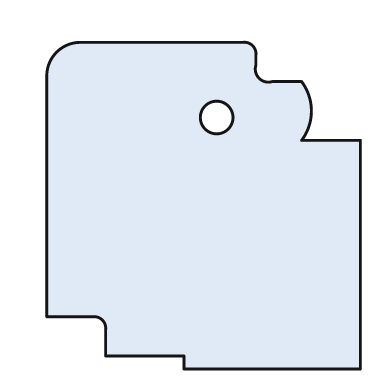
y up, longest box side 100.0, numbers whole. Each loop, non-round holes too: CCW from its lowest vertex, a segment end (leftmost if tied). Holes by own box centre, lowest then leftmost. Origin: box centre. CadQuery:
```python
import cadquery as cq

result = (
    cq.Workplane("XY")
    .moveTo(-6.0, -50.0)
    .lineTo(48.0, -50.0)
    .lineTo(48.0, 20.0)
    .lineTo(30.0, 20.0)
    .threePointArc((33.0, 29.0), (30.0, 38.0))
    .lineTo(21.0, 38.0)
    .threePointArc((17.0, 39.0), (16.0, 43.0))
    .lineTo(16.0, 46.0)
    .threePointArc((15.0, 49.0), (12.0, 50.0))
    .lineTo(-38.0, 50.0)
    .threePointArc((-45.0, 47.0), (-48.0, 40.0))
    .lineTo(-48.0, -34.0)
    .lineTo(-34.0, -34.0)
    .threePointArc((-31.0, -35.0), (-30.0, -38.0))
    .lineTo(-30.0, -46.0)
    .lineTo(-6.0, -46.0)
    .close()
    .moveTo(4.0, 27.0)
    .circle(5.0)
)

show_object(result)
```